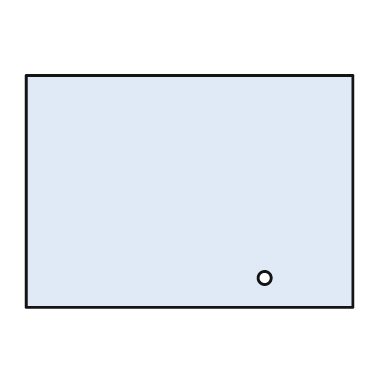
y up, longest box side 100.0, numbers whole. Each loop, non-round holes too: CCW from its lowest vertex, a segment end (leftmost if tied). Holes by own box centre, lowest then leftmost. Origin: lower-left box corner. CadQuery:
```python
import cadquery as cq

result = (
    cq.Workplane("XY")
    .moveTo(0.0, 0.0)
    .lineTo(100.0, 0.0)
    .lineTo(100.0, 71.0)
    .lineTo(0.0, 71.0)
    .close()
    .moveTo(73.0, 9.0)
    .circle(2.0)
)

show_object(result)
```